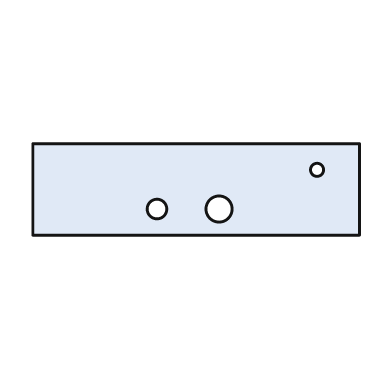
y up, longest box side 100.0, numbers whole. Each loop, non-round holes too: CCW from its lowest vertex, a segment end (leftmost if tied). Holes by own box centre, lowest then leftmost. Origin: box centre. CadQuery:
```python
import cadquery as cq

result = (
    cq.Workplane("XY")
    .moveTo(-50.0, -14.0)
    .lineTo(50.0, -14.0)
    .lineTo(50.0, 14.0)
    .lineTo(-50.0, 14.0)
    .close()
    .moveTo(-12.0, -6.0)
    .circle(3.0)
    .moveTo(7.0, -6.0)
    .circle(4.0)
    .moveTo(37.0, 6.0)
    .circle(2.0)
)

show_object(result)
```